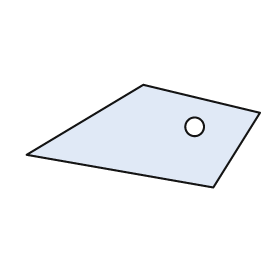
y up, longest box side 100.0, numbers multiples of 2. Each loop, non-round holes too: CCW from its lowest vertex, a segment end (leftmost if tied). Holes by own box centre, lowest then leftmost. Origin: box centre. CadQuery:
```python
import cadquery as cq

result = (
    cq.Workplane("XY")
    .moveTo(30.0, -22.0)
    .lineTo(50.0, 10.0)
    .lineTo(0.0, 22.0)
    .lineTo(-50.0, -8.0)
    .close()
    .moveTo(22.0, 4.0)
    .circle(4.0)
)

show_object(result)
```